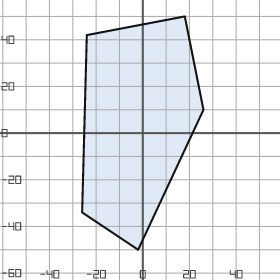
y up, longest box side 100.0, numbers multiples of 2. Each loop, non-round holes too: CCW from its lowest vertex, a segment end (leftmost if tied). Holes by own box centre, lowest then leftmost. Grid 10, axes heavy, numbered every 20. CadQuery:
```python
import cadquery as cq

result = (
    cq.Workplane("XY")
    .moveTo(-2.0, -50.0)
    .lineTo(26.0, 10.0)
    .lineTo(18.0, 50.0)
    .lineTo(-24.0, 42.0)
    .lineTo(-26.0, -34.0)
    .close()
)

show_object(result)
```